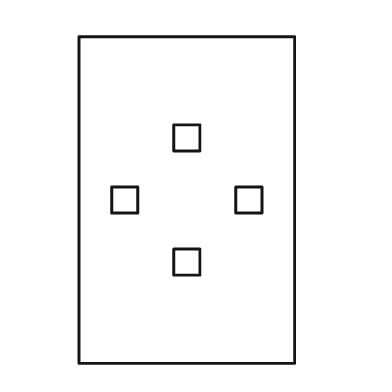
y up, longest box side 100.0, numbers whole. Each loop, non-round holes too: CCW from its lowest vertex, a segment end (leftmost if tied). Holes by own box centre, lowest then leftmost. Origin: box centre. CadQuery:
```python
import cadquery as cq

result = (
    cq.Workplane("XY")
    .moveTo(-33.0, -50.0)
    .lineTo(33.0, -50.0)
    .lineTo(33.0, 50.0)
    .lineTo(-33.0, 50.0)
    .close()
    .moveTo(-4.0, -23.0)
    .lineTo(4.0, -23.0)
    .lineTo(4.0, -15.0)
    .lineTo(-4.0, -15.0)
    .close()
    .moveTo(-23.0, -4.0)
    .lineTo(-15.0, -4.0)
    .lineTo(-15.0, 4.0)
    .lineTo(-23.0, 4.0)
    .close()
    .moveTo(15.0, -4.0)
    .lineTo(23.0, -4.0)
    .lineTo(23.0, 4.0)
    .lineTo(15.0, 4.0)
    .close()
    .moveTo(-4.0, 15.0)
    .lineTo(4.0, 15.0)
    .lineTo(4.0, 23.0)
    .lineTo(-4.0, 23.0)
    .close()
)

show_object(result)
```